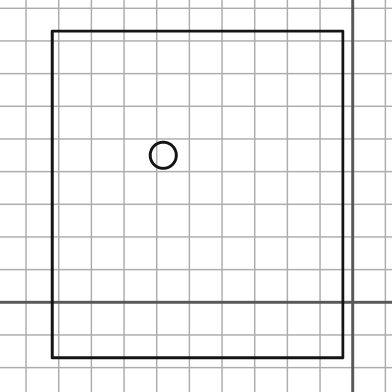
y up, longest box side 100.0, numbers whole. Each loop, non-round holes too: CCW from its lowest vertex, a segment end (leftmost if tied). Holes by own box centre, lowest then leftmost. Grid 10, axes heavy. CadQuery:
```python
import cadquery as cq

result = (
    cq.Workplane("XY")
    .moveTo(-92.0, -17.0)
    .lineTo(-3.0, -17.0)
    .lineTo(-3.0, 83.0)
    .lineTo(-92.0, 83.0)
    .close()
    .moveTo(-58.0, 45.0)
    .circle(4.0)
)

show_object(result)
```